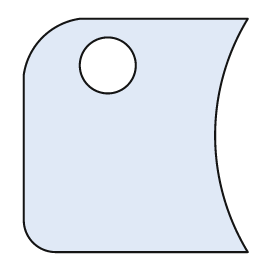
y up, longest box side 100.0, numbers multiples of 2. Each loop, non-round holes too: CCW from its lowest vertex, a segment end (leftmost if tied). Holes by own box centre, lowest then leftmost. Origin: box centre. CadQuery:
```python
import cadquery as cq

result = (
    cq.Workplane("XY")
    .moveTo(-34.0, -50.0)
    .lineTo(48.0, -50.0)
    .threePointArc((34.0, 0.0), (48.0, 50.0))
    .lineTo(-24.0, 50.0)
    .threePointArc((-40.0, 42.0), (-48.0, 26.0))
    .lineTo(-48.0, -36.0)
    .threePointArc((-44.0, -46.0), (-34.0, -50.0))
    .close()
    .moveTo(-12.0, 30.0)
    .circle(12.0)
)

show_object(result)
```